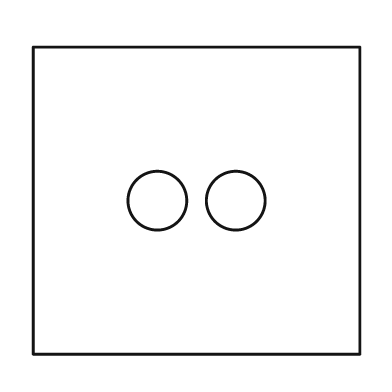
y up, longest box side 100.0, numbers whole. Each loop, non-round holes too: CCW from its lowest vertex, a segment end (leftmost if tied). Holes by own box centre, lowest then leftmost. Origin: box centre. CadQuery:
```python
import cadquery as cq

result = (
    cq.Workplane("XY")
    .moveTo(-50.0, -47.0)
    .lineTo(50.0, -47.0)
    .lineTo(50.0, 47.0)
    .lineTo(-50.0, 47.0)
    .close()
    .moveTo(-12.0, 0.0)
    .circle(9.0)
    .moveTo(12.0, 0.0)
    .circle(9.0)
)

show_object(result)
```